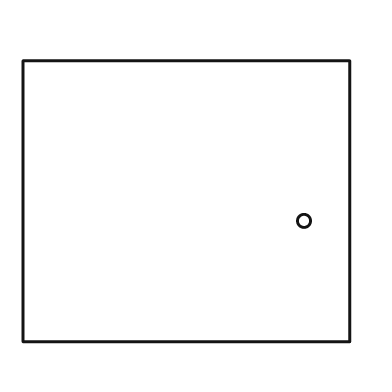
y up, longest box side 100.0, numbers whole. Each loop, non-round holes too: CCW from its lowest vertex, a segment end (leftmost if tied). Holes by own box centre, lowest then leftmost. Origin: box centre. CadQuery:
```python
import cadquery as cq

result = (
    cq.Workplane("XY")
    .moveTo(-50.0, -43.0)
    .lineTo(50.0, -43.0)
    .lineTo(50.0, 43.0)
    .lineTo(-50.0, 43.0)
    .close()
    .moveTo(36.0, -6.0)
    .circle(2.0)
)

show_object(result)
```